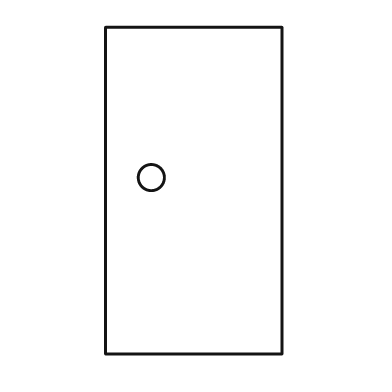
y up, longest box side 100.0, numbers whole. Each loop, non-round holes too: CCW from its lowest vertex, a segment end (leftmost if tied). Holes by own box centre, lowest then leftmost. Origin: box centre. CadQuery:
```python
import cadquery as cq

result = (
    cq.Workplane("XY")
    .moveTo(-27.0, -50.0)
    .lineTo(27.0, -50.0)
    .lineTo(27.0, 50.0)
    .lineTo(-27.0, 50.0)
    .close()
    .moveTo(-13.0, 4.0)
    .circle(4.0)
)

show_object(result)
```